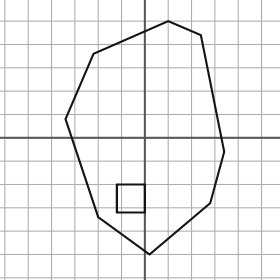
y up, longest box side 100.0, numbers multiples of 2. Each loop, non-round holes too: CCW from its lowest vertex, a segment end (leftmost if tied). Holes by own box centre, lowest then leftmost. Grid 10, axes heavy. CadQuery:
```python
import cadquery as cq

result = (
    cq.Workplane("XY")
    .moveTo(2.0, -50.0)
    .lineTo(28.0, -28.0)
    .lineTo(34.0, -6.0)
    .lineTo(24.0, 44.0)
    .lineTo(10.0, 50.0)
    .lineTo(-22.0, 36.0)
    .lineTo(-34.0, 8.0)
    .lineTo(-20.0, -34.0)
    .close()
    .moveTo(-12.0, -32.0)
    .lineTo(0.0, -32.0)
    .lineTo(0.0, -20.0)
    .lineTo(-12.0, -20.0)
    .close()
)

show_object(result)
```